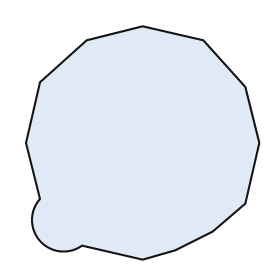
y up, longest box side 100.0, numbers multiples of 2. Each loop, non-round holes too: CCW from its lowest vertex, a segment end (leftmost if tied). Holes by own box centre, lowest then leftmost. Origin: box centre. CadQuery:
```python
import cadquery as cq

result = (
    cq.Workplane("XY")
    .moveTo(0.0, -50.0)
    .lineTo(14.0, -46.0)
    .lineTo(30.0, -38.0)
    .lineTo(44.0, -26.0)
    .lineTo(50.0, 0.0)
    .lineTo(44.0, 24.0)
    .lineTo(26.0, 44.0)
    .lineTo(0.0, 50.0)
    .lineTo(-24.0, 44.0)
    .lineTo(-44.0, 26.0)
    .lineTo(-50.0, 0.0)
    .lineTo(-44.0, -24.0)
    .threePointArc((-44.0, -42.0), (-26.0, -44.0))
    .close()
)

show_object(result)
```